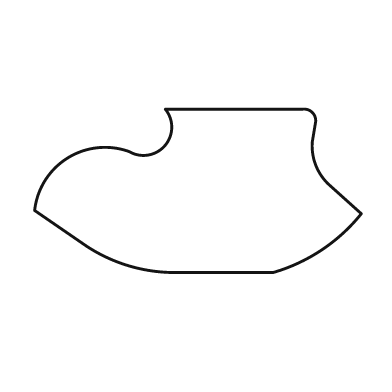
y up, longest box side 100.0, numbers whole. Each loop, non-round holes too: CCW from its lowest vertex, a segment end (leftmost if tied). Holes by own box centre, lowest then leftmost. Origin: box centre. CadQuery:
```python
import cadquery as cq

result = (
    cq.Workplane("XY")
    .moveTo(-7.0, -25.0)
    .lineTo(23.0, -25.0)
    .threePointArc((38.0, -18.0), (50.0, -7.0))
    .lineTo(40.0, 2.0)
    .threePointArc((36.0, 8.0), (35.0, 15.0))
    .lineTo(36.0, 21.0)
    .threePointArc((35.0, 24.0), (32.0, 25.0))
    .lineTo(-10.0, 25.0)
    .threePointArc((-10.0, 14.0), (-21.0, 12.0))
    .threePointArc((-40.0, 10.0), (-50.0, -6.0))
    .lineTo(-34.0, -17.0)
    .threePointArc((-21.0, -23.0), (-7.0, -25.0))
    .close()
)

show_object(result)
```